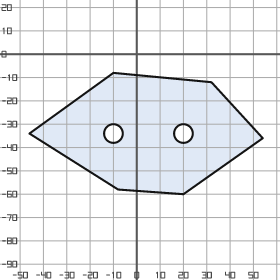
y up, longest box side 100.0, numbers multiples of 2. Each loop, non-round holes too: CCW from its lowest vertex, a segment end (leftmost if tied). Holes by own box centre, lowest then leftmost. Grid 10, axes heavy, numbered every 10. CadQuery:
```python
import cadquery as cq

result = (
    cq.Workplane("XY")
    .moveTo(20.0, -60.0)
    .lineTo(54.0, -36.0)
    .lineTo(32.0, -12.0)
    .lineTo(-10.0, -8.0)
    .lineTo(-46.0, -34.0)
    .lineTo(-8.0, -58.0)
    .close()
    .moveTo(-10.0, -34.0)
    .circle(4.0)
    .moveTo(20.0, -34.0)
    .circle(4.0)
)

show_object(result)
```